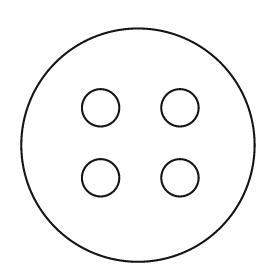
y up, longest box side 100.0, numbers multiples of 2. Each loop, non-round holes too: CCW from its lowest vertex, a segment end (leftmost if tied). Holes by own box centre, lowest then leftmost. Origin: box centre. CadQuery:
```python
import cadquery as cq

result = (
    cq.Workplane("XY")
    .moveTo(0.0, 0.0)
    .circle(50.0)
    .moveTo(-16.0, -14.0)
    .circle(8.0)
    .moveTo(18.0, -14.0)
    .circle(8.0)
    .moveTo(-16.0, 16.0)
    .circle(8.0)
    .moveTo(18.0, 16.0)
    .circle(8.0)
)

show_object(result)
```